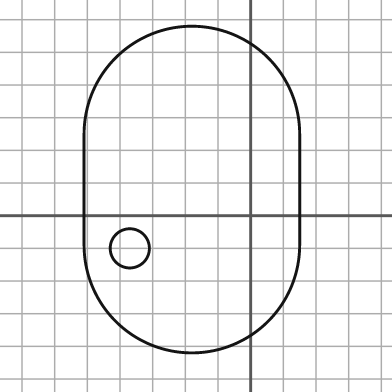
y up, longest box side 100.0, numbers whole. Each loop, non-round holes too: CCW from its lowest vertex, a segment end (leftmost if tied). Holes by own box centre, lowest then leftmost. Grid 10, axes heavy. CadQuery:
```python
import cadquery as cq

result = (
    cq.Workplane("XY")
    .moveTo(-51.0, -9.0)
    .threePointArc((-18.0, -42.0), (15.0, -9.0))
    .lineTo(15.0, 25.0)
    .threePointArc((-18.0, 58.0), (-51.0, 25.0))
    .close()
    .moveTo(-37.0, -10.0)
    .circle(6.0)
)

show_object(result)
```